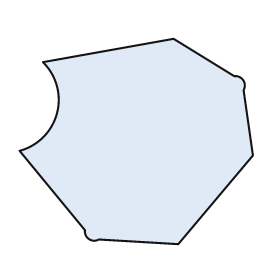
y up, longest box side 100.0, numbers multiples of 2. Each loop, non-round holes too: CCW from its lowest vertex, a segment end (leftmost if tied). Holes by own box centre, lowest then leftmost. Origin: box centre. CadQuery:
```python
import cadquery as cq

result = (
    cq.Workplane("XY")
    .moveTo(18.0, -44.0)
    .lineTo(50.0, -6.0)
    .lineTo(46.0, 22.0)
    .threePointArc((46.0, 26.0), (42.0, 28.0))
    .lineTo(16.0, 44.0)
    .lineTo(-40.0, 34.0)
    .threePointArc((-34.0, 12.0), (-50.0, -4.0))
    .lineTo(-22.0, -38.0)
    .threePointArc((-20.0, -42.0), (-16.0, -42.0))
    .close()
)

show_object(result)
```